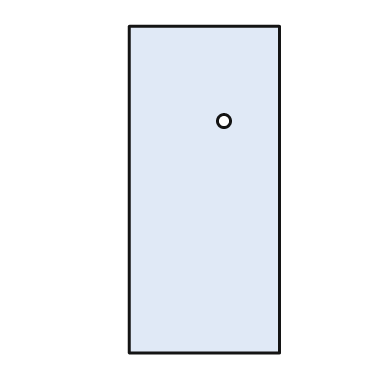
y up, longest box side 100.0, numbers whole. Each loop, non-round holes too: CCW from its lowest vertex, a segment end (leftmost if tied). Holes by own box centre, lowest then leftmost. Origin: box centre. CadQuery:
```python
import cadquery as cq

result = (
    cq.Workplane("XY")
    .moveTo(-23.0, -50.0)
    .lineTo(23.0, -50.0)
    .lineTo(23.0, 50.0)
    .lineTo(-23.0, 50.0)
    .close()
    .moveTo(6.0, 21.0)
    .circle(2.0)
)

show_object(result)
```